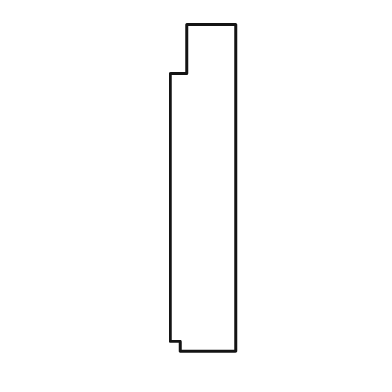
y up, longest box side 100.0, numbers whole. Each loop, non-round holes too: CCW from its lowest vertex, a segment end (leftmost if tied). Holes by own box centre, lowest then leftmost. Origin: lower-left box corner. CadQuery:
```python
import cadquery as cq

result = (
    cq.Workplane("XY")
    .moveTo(3.0, 0.0)
    .lineTo(20.0, 0.0)
    .lineTo(20.0, 100.0)
    .lineTo(5.0, 100.0)
    .lineTo(5.0, 85.0)
    .lineTo(0.0, 85.0)
    .lineTo(0.0, 3.0)
    .lineTo(3.0, 3.0)
    .close()
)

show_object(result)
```